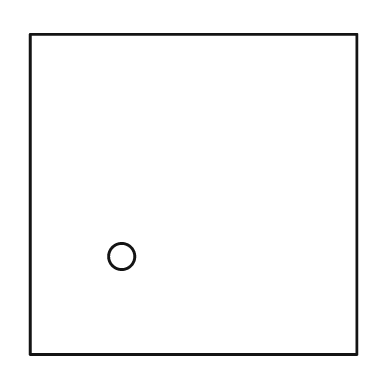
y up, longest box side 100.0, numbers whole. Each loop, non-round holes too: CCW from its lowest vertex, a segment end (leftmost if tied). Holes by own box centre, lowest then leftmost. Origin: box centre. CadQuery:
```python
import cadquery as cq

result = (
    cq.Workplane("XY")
    .moveTo(-50.0, -49.0)
    .lineTo(50.0, -49.0)
    .lineTo(50.0, 49.0)
    .lineTo(-50.0, 49.0)
    .close()
    .moveTo(-22.0, -19.0)
    .circle(4.0)
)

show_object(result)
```